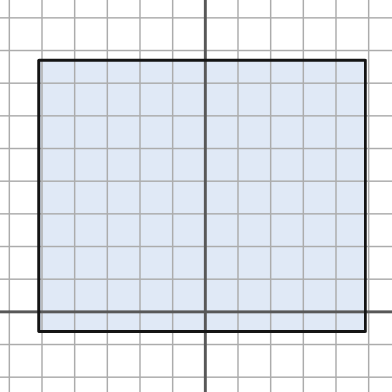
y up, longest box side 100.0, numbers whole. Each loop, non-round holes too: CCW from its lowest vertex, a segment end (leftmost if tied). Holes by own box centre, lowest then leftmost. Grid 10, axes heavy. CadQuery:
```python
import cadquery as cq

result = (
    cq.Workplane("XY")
    .moveTo(-51.0, -6.0)
    .lineTo(49.0, -6.0)
    .lineTo(49.0, 77.0)
    .lineTo(-51.0, 77.0)
    .close()
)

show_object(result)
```